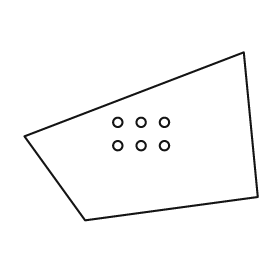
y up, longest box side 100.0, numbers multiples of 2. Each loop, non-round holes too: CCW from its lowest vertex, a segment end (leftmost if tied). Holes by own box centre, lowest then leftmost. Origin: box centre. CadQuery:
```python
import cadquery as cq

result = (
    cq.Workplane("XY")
    .moveTo(-24.0, -36.0)
    .lineTo(50.0, -26.0)
    .lineTo(44.0, 36.0)
    .lineTo(-50.0, 0.0)
    .close()
    .moveTo(-10.0, -4.0)
    .circle(2.0)
    .moveTo(0.0, -4.0)
    .circle(2.0)
    .moveTo(10.0, -4.0)
    .circle(2.0)
    .moveTo(-10.0, 6.0)
    .circle(2.0)
    .moveTo(0.0, 6.0)
    .circle(2.0)
    .moveTo(10.0, 6.0)
    .circle(2.0)
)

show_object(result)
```